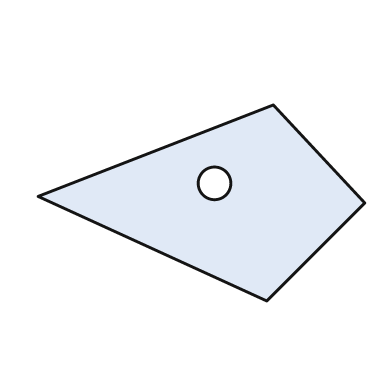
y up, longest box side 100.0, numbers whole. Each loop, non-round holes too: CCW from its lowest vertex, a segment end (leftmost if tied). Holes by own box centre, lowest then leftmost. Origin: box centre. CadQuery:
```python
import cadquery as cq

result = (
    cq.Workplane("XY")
    .moveTo(20.0, -30.0)
    .lineTo(50.0, 0.0)
    .lineTo(22.0, 30.0)
    .lineTo(-50.0, 2.0)
    .close()
    .moveTo(4.0, 6.0)
    .circle(5.0)
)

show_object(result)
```